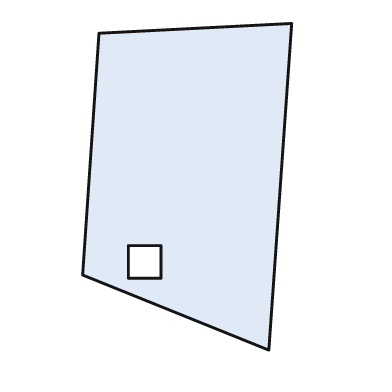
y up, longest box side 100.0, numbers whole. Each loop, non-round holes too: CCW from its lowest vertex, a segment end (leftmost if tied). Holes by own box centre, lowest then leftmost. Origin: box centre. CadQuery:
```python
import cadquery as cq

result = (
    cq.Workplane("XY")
    .moveTo(25.0, -50.0)
    .lineTo(32.0, 50.0)
    .lineTo(-27.0, 47.0)
    .lineTo(-32.0, -27.0)
    .close()
    .moveTo(-18.0, -28.0)
    .lineTo(-8.0, -28.0)
    .lineTo(-8.0, -18.0)
    .lineTo(-18.0, -18.0)
    .close()
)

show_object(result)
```